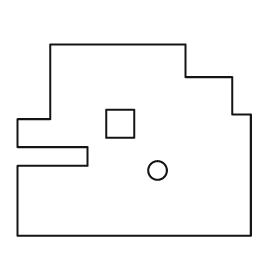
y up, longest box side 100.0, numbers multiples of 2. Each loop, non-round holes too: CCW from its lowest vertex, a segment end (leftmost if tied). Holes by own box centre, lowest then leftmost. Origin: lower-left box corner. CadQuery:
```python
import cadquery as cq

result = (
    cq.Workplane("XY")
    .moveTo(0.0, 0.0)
    .lineTo(100.0, 0.0)
    .lineTo(100.0, 52.0)
    .lineTo(92.0, 52.0)
    .lineTo(92.0, 68.0)
    .lineTo(72.0, 68.0)
    .lineTo(72.0, 82.0)
    .lineTo(14.0, 82.0)
    .lineTo(14.0, 50.0)
    .lineTo(0.0, 50.0)
    .lineTo(0.0, 38.0)
    .lineTo(30.0, 38.0)
    .lineTo(30.0, 30.0)
    .lineTo(0.0, 30.0)
    .close()
    .moveTo(60.0, 28.0)
    .circle(4.0)
    .moveTo(38.0, 42.0)
    .lineTo(50.0, 42.0)
    .lineTo(50.0, 54.0)
    .lineTo(38.0, 54.0)
    .close()
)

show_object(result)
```